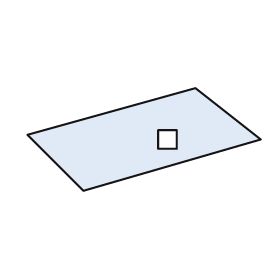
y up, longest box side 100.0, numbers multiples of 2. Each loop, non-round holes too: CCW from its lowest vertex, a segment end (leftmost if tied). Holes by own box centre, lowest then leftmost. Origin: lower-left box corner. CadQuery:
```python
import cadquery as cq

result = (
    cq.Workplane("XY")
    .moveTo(24.0, 0.0)
    .lineTo(100.0, 22.0)
    .lineTo(72.0, 44.0)
    .lineTo(0.0, 24.0)
    .close()
    .moveTo(56.0, 18.0)
    .lineTo(64.0, 18.0)
    .lineTo(64.0, 26.0)
    .lineTo(56.0, 26.0)
    .close()
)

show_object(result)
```